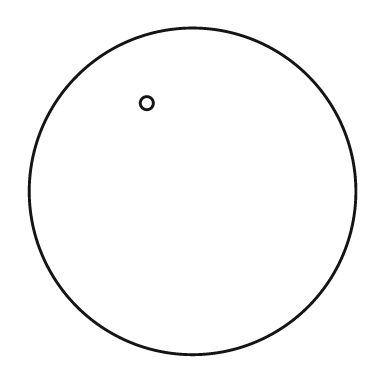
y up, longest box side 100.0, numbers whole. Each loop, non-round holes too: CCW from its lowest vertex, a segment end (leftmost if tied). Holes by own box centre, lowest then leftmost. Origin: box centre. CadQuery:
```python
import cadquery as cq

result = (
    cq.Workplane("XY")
    .moveTo(0.0, 0.0)
    .circle(50.0)
    .moveTo(-14.0, 27.0)
    .circle(2.0)
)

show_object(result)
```